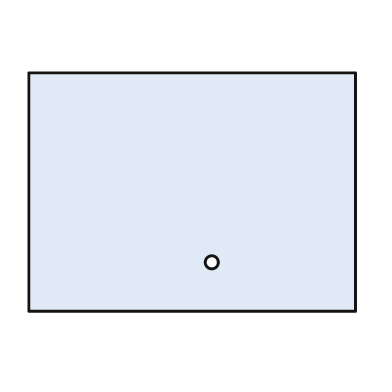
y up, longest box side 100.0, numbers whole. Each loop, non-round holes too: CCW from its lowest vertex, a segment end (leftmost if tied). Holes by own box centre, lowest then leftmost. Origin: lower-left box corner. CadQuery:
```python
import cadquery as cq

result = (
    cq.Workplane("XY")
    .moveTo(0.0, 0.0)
    .lineTo(100.0, 0.0)
    .lineTo(100.0, 73.0)
    .lineTo(0.0, 73.0)
    .close()
    .moveTo(56.0, 15.0)
    .circle(2.0)
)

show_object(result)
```